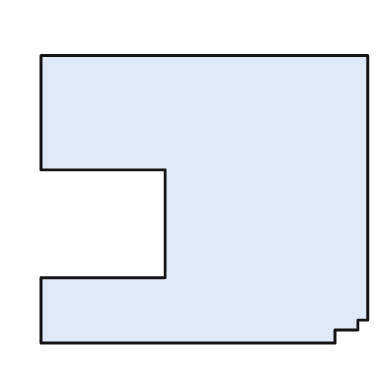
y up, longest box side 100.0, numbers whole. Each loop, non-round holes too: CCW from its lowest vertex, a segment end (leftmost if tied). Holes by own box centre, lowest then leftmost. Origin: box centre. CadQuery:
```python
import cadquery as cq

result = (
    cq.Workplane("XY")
    .moveTo(-50.0, -44.0)
    .lineTo(40.0, -44.0)
    .lineTo(40.0, -40.0)
    .lineTo(47.0, -40.0)
    .lineTo(47.0, -37.0)
    .lineTo(50.0, -37.0)
    .lineTo(50.0, 44.0)
    .lineTo(-50.0, 44.0)
    .lineTo(-50.0, 9.0)
    .lineTo(-12.0, 9.0)
    .lineTo(-12.0, -24.0)
    .lineTo(-50.0, -24.0)
    .close()
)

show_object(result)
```